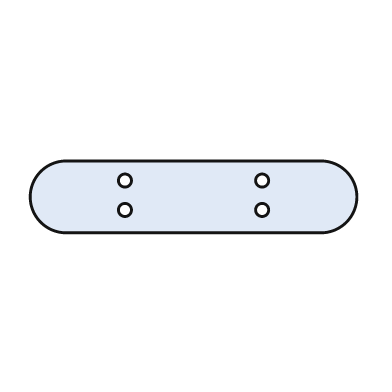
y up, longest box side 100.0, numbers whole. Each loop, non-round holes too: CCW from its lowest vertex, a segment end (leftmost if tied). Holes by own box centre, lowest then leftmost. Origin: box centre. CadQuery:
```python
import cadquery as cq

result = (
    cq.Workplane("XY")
    .moveTo(-39.0, -11.0)
    .lineTo(39.0, -11.0)
    .threePointArc((50.0, 0.0), (39.0, 11.0))
    .lineTo(-39.0, 11.0)
    .threePointArc((-50.0, 0.0), (-39.0, -11.0))
    .close()
    .moveTo(-21.0, -4.0)
    .circle(2.0)
    .moveTo(21.0, -4.0)
    .circle(2.0)
    .moveTo(-21.0, 5.0)
    .circle(2.0)
    .moveTo(21.0, 5.0)
    .circle(2.0)
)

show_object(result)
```